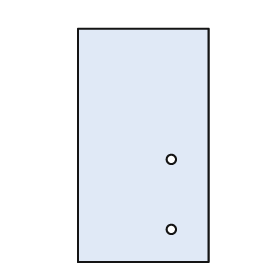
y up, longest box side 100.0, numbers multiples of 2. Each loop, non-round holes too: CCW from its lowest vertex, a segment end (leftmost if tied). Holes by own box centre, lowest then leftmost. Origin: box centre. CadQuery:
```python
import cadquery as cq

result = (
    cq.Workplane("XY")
    .moveTo(-28.0, -50.0)
    .lineTo(28.0, -50.0)
    .lineTo(28.0, 50.0)
    .lineTo(-28.0, 50.0)
    .close()
    .moveTo(12.0, -36.0)
    .circle(2.0)
    .moveTo(12.0, -6.0)
    .circle(2.0)
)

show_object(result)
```